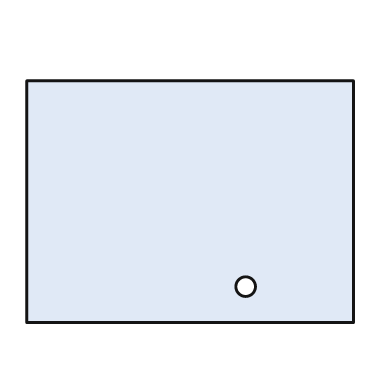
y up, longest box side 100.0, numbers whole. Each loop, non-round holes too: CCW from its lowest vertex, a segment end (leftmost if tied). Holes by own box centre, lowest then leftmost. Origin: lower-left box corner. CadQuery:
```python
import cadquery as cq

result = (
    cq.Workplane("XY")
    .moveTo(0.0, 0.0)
    .lineTo(100.0, 0.0)
    .lineTo(100.0, 74.0)
    .lineTo(0.0, 74.0)
    .close()
    .moveTo(67.0, 11.0)
    .circle(3.0)
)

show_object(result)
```